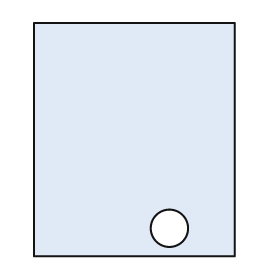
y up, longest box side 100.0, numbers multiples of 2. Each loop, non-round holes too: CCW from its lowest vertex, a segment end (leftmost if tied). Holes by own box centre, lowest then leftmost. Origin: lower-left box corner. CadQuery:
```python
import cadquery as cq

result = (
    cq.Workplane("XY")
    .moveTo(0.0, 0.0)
    .lineTo(86.0, 0.0)
    .lineTo(86.0, 100.0)
    .lineTo(0.0, 100.0)
    .close()
    .moveTo(58.0, 12.0)
    .circle(8.0)
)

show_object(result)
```